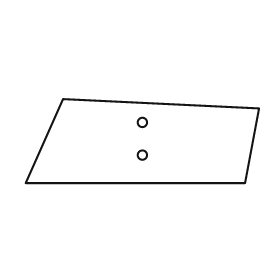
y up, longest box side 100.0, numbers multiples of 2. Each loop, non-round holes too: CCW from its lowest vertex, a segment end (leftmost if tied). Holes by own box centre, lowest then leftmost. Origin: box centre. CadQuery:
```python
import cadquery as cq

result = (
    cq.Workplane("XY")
    .moveTo(-50.0, -18.0)
    .lineTo(44.0, -18.0)
    .lineTo(50.0, 14.0)
    .lineTo(-34.0, 18.0)
    .close()
    .moveTo(0.0, -6.0)
    .circle(2.0)
    .moveTo(0.0, 8.0)
    .circle(2.0)
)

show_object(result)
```